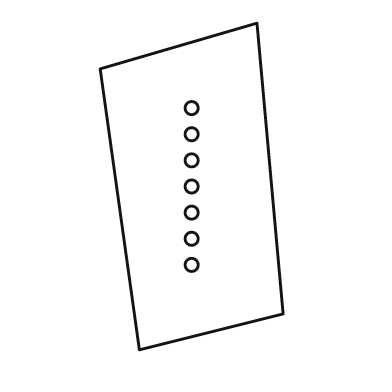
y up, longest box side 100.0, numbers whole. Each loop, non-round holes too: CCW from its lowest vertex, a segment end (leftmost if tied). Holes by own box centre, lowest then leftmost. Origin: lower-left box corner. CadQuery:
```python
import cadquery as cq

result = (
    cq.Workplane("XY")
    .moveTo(12.0, 0.0)
    .lineTo(56.0, 11.0)
    .lineTo(48.0, 100.0)
    .lineTo(0.0, 86.0)
    .close()
    .moveTo(28.0, 26.0)
    .circle(2.0)
    .moveTo(28.0, 34.0)
    .circle(2.0)
    .moveTo(28.0, 42.0)
    .circle(2.0)
    .moveTo(28.0, 50.0)
    .circle(2.0)
    .moveTo(28.0, 58.0)
    .circle(2.0)
    .moveTo(28.0, 66.0)
    .circle(2.0)
    .moveTo(28.0, 74.0)
    .circle(2.0)
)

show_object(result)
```